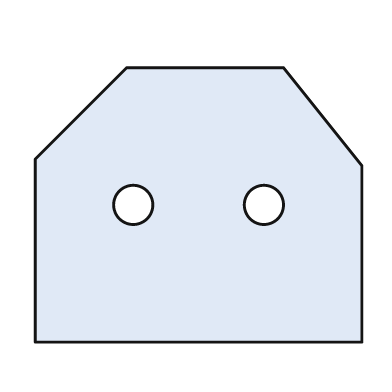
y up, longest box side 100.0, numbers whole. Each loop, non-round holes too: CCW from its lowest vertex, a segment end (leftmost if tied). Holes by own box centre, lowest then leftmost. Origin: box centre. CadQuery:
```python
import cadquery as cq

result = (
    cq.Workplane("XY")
    .moveTo(-50.0, -42.0)
    .lineTo(50.0, -42.0)
    .lineTo(50.0, 12.0)
    .lineTo(26.0, 42.0)
    .lineTo(-22.0, 42.0)
    .lineTo(-50.0, 14.0)
    .close()
    .moveTo(-20.0, 0.0)
    .circle(6.0)
    .moveTo(20.0, 0.0)
    .circle(6.0)
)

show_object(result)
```